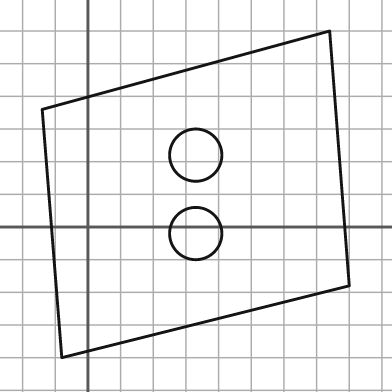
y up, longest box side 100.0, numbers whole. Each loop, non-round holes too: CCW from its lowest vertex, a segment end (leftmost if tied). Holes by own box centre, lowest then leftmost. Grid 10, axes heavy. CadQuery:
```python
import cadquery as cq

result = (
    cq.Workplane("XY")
    .moveTo(-8.0, -40.0)
    .lineTo(80.0, -18.0)
    .lineTo(74.0, 60.0)
    .lineTo(-14.0, 36.0)
    .close()
    .moveTo(33.0, -2.0)
    .circle(8.0)
    .moveTo(33.0, 22.0)
    .circle(8.0)
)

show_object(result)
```